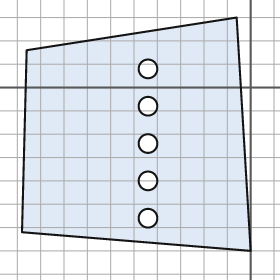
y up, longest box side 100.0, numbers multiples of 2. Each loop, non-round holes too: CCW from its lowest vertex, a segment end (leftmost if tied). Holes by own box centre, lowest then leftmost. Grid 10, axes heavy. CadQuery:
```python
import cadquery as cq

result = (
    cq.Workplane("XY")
    .moveTo(0.0, -70.0)
    .lineTo(-6.0, 30.0)
    .lineTo(-96.0, 16.0)
    .lineTo(-98.0, -62.0)
    .close()
    .moveTo(-44.0, -56.0)
    .circle(4.0)
    .moveTo(-44.0, -40.0)
    .circle(4.0)
    .moveTo(-44.0, -24.0)
    .circle(4.0)
    .moveTo(-44.0, -8.0)
    .circle(4.0)
    .moveTo(-44.0, 8.0)
    .circle(4.0)
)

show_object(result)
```